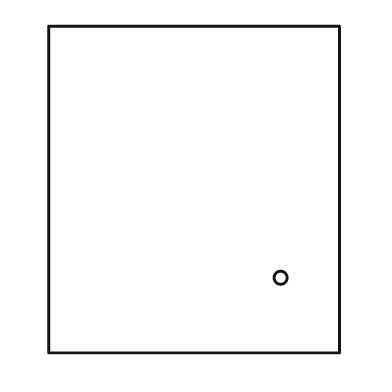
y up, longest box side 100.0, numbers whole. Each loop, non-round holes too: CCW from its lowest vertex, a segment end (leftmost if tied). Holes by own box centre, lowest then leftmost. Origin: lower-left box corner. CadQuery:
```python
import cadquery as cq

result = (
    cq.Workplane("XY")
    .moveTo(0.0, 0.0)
    .lineTo(89.0, 0.0)
    .lineTo(89.0, 100.0)
    .lineTo(0.0, 100.0)
    .close()
    .moveTo(71.0, 23.0)
    .circle(2.0)
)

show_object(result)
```